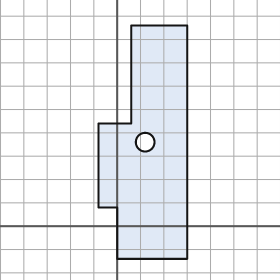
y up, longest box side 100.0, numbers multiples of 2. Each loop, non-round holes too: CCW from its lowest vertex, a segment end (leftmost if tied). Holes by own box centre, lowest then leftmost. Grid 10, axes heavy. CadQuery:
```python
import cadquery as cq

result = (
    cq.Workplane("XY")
    .moveTo(0.0, -14.0)
    .lineTo(30.0, -14.0)
    .lineTo(30.0, 86.0)
    .lineTo(6.0, 86.0)
    .lineTo(6.0, 44.0)
    .lineTo(-8.0, 44.0)
    .lineTo(-8.0, 8.0)
    .lineTo(0.0, 8.0)
    .close()
    .moveTo(12.0, 36.0)
    .circle(4.0)
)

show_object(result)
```